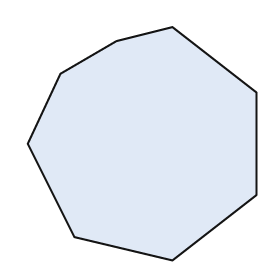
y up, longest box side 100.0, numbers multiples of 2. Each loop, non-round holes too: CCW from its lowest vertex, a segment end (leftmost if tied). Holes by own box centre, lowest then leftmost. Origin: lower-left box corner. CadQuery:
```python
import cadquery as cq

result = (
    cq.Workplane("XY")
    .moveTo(62.0, 0.0)
    .lineTo(98.0, 28.0)
    .lineTo(98.0, 72.0)
    .lineTo(62.0, 100.0)
    .lineTo(38.0, 94.0)
    .lineTo(14.0, 80.0)
    .lineTo(0.0, 50.0)
    .lineTo(20.0, 10.0)
    .close()
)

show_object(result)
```